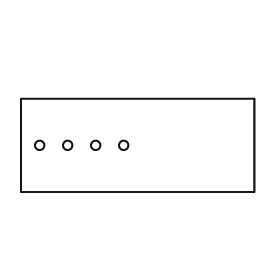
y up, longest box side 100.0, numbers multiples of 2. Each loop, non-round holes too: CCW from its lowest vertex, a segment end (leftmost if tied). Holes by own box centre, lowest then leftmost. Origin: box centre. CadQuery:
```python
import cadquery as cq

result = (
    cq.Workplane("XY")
    .moveTo(-50.0, -20.0)
    .lineTo(50.0, -20.0)
    .lineTo(50.0, 20.0)
    .lineTo(-50.0, 20.0)
    .close()
    .moveTo(-42.0, 0.0)
    .circle(2.0)
    .moveTo(-30.0, 0.0)
    .circle(2.0)
    .moveTo(-18.0, 0.0)
    .circle(2.0)
    .moveTo(-6.0, 0.0)
    .circle(2.0)
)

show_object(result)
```